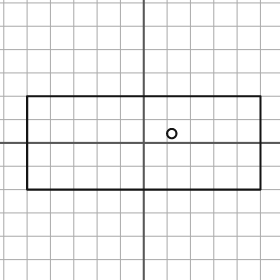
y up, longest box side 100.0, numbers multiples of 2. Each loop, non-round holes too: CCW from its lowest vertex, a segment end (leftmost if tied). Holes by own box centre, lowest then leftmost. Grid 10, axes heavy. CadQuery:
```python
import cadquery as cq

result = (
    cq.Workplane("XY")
    .moveTo(-50.0, -20.0)
    .lineTo(50.0, -20.0)
    .lineTo(50.0, 20.0)
    .lineTo(-50.0, 20.0)
    .close()
    .moveTo(12.0, 4.0)
    .circle(2.0)
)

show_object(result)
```